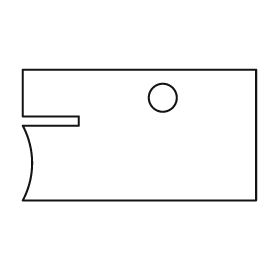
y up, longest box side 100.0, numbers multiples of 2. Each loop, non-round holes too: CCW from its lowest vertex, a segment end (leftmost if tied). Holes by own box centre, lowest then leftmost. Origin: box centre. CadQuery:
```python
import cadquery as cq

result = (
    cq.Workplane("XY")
    .moveTo(-50.0, -28.0)
    .lineTo(50.0, -28.0)
    .lineTo(50.0, 28.0)
    .lineTo(-50.0, 28.0)
    .lineTo(-50.0, 8.0)
    .lineTo(-26.0, 8.0)
    .lineTo(-26.0, 4.0)
    .lineTo(-50.0, 4.0)
    .threePointArc((-46.0, -12.0), (-50.0, -28.0))
    .close()
    .moveTo(10.0, 16.0)
    .circle(6.0)
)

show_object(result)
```